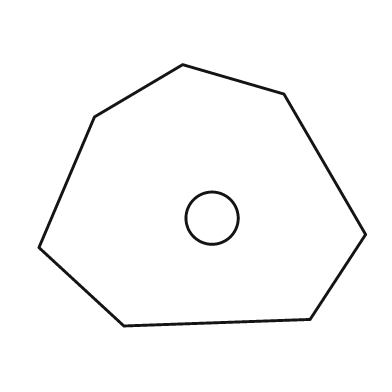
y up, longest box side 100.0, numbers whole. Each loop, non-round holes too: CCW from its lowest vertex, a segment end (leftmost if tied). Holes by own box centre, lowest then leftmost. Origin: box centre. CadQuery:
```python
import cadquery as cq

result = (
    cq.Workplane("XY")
    .moveTo(-24.0, -40.0)
    .lineTo(33.0, -38.0)
    .lineTo(50.0, -12.0)
    .lineTo(25.0, 31.0)
    .lineTo(-6.0, 40.0)
    .lineTo(-33.0, 24.0)
    .lineTo(-50.0, -16.0)
    .close()
    .moveTo(3.0, -7.0)
    .circle(8.0)
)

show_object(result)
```